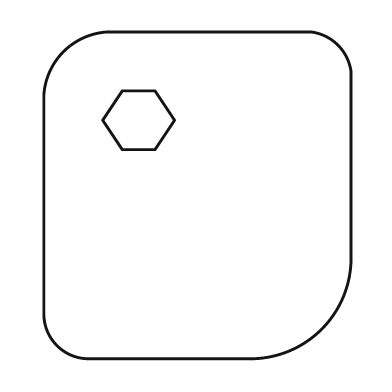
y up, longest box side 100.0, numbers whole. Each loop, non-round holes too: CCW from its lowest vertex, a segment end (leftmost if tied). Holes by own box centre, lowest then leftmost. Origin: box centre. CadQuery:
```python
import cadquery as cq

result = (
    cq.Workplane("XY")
    .moveTo(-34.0, -50.0)
    .lineTo(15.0, -50.0)
    .threePointArc((38.0, -41.0), (47.0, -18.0))
    .lineTo(47.0, 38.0)
    .threePointArc((43.0, 46.0), (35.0, 50.0))
    .lineTo(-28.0, 50.0)
    .threePointArc((-41.0, 44.0), (-47.0, 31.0))
    .lineTo(-47.0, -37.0)
    .threePointArc((-43.0, -46.0), (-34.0, -50.0))
    .close()
    .moveTo(-23.0, 14.0)
    .lineTo(-13.0, 14.0)
    .lineTo(-7.0, 23.0)
    .lineTo(-13.0, 32.0)
    .lineTo(-23.0, 32.0)
    .lineTo(-29.0, 23.0)
    .close()
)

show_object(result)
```